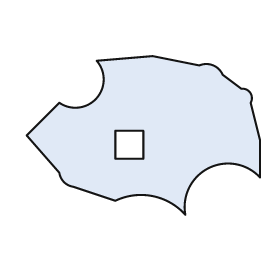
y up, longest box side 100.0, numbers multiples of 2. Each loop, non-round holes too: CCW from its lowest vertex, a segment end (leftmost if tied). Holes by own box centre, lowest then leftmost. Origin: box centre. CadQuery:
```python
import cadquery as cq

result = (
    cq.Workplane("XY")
    .moveTo(18.0, -34.0)
    .threePointArc((28.0, -14.0), (50.0, -18.0))
    .lineTo(50.0, -2.0)
    .lineTo(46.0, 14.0)
    .threePointArc((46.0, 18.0), (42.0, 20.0))
    .lineTo(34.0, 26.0)
    .threePointArc((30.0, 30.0), (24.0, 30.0))
    .lineTo(4.0, 34.0)
    .lineTo(-20.0, 32.0)
    .threePointArc((-20.0, 16.0), (-36.0, 14.0))
    .lineTo(-50.0, 0.0)
    .lineTo(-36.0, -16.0)
    .threePointArc((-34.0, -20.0), (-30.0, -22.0))
    .lineTo(-12.0, -28.0)
    .threePointArc((4.0, -26.0), (18.0, -34.0))
    .close()
    .moveTo(-12.0, -10.0)
    .lineTo(0.0, -10.0)
    .lineTo(0.0, 2.0)
    .lineTo(-12.0, 2.0)
    .close()
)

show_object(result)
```